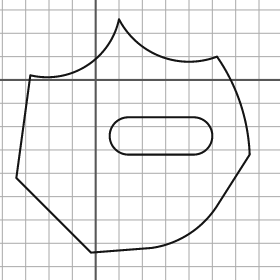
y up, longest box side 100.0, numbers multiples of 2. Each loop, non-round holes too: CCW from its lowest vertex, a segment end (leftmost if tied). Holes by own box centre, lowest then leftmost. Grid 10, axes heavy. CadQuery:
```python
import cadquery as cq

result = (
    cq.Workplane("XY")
    .moveTo(-2.0, -74.0)
    .lineTo(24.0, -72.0)
    .threePointArc((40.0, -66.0), (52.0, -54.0))
    .lineTo(66.0, -32.0)
    .threePointArc((62.0, -10.0), (52.0, 10.0))
    .threePointArc((28.0, 10.0), (10.0, 26.0))
    .threePointArc((-4.0, 6.0), (-28.0, 2.0))
    .lineTo(-34.0, -42.0)
    .close()
    .moveTo(14.0, -32.0)
    .lineTo(42.0, -32.0)
    .threePointArc((50.0, -24.0), (42.0, -16.0))
    .lineTo(14.0, -16.0)
    .threePointArc((6.0, -24.0), (14.0, -32.0))
    .close()
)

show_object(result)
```